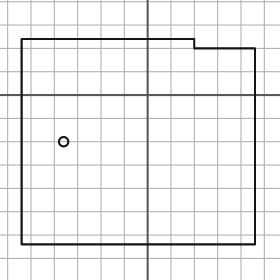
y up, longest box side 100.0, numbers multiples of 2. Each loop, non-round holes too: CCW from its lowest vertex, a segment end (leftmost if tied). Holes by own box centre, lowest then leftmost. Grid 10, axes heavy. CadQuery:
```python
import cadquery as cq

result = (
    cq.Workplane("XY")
    .moveTo(-54.0, -64.0)
    .lineTo(46.0, -64.0)
    .lineTo(46.0, 20.0)
    .lineTo(20.0, 20.0)
    .lineTo(20.0, 24.0)
    .lineTo(-54.0, 24.0)
    .close()
    .moveTo(-36.0, -20.0)
    .circle(2.0)
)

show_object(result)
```